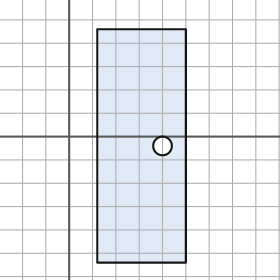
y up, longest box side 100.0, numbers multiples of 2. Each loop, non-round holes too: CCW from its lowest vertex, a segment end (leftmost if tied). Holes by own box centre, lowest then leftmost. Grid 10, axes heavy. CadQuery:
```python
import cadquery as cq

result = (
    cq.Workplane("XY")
    .moveTo(12.0, -54.0)
    .lineTo(50.0, -54.0)
    .lineTo(50.0, 46.0)
    .lineTo(12.0, 46.0)
    .close()
    .moveTo(40.0, -4.0)
    .circle(4.0)
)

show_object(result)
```